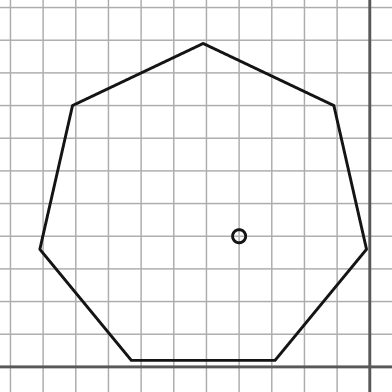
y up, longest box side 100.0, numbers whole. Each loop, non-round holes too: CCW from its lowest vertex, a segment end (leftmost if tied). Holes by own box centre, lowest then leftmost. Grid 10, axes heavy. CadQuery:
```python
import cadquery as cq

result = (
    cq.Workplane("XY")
    .moveTo(-73.0, 2.0)
    .lineTo(-29.0, 2.0)
    .lineTo(-1.0, 36.0)
    .lineTo(-11.0, 80.0)
    .lineTo(-51.0, 99.0)
    .lineTo(-91.0, 80.0)
    .lineTo(-101.0, 36.0)
    .close()
    .moveTo(-40.0, 40.0)
    .circle(2.0)
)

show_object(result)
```